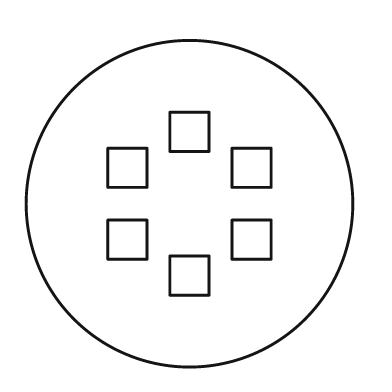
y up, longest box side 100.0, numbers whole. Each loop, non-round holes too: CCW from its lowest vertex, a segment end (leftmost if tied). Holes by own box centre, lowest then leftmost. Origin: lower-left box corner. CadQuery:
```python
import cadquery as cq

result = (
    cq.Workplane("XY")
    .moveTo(50.0, 50.0)
    .circle(50.0)
    .moveTo(44.0, 22.0)
    .lineTo(56.0, 22.0)
    .lineTo(56.0, 34.0)
    .lineTo(44.0, 34.0)
    .close()
    .moveTo(25.0, 33.0)
    .lineTo(37.0, 33.0)
    .lineTo(37.0, 45.0)
    .lineTo(25.0, 45.0)
    .close()
    .moveTo(63.0, 33.0)
    .lineTo(75.0, 33.0)
    .lineTo(75.0, 45.0)
    .lineTo(63.0, 45.0)
    .close()
    .moveTo(25.0, 55.0)
    .lineTo(37.0, 55.0)
    .lineTo(37.0, 67.0)
    .lineTo(25.0, 67.0)
    .close()
    .moveTo(63.0, 55.0)
    .lineTo(75.0, 55.0)
    .lineTo(75.0, 67.0)
    .lineTo(63.0, 67.0)
    .close()
    .moveTo(44.0, 66.0)
    .lineTo(56.0, 66.0)
    .lineTo(56.0, 78.0)
    .lineTo(44.0, 78.0)
    .close()
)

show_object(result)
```